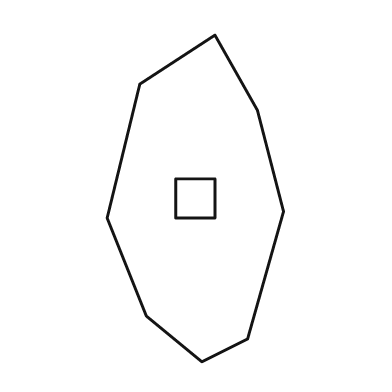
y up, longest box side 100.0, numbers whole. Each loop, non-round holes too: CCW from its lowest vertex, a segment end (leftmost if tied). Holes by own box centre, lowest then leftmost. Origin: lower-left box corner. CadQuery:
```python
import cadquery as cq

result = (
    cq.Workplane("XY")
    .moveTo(29.0, 0.0)
    .lineTo(43.0, 7.0)
    .lineTo(54.0, 46.0)
    .lineTo(46.0, 77.0)
    .lineTo(33.0, 100.0)
    .lineTo(10.0, 85.0)
    .lineTo(0.0, 44.0)
    .lineTo(12.0, 14.0)
    .close()
    .moveTo(21.0, 44.0)
    .lineTo(33.0, 44.0)
    .lineTo(33.0, 56.0)
    .lineTo(21.0, 56.0)
    .close()
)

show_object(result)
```